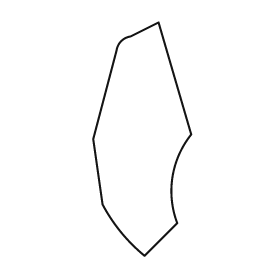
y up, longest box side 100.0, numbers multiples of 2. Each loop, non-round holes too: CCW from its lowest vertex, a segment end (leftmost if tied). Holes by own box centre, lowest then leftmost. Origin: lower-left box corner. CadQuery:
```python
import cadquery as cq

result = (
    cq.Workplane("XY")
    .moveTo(22.0, 0.0)
    .lineTo(36.0, 14.0)
    .threePointArc((34.0, 34.0), (42.0, 52.0))
    .lineTo(28.0, 100.0)
    .lineTo(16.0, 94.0)
    .threePointArc((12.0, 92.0), (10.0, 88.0))
    .lineTo(0.0, 50.0)
    .lineTo(4.0, 22.0)
    .threePointArc((12.0, 10.0), (22.0, 0.0))
    .close()
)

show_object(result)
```